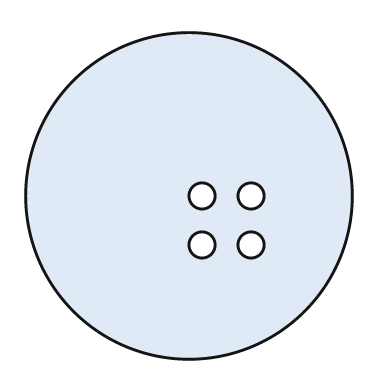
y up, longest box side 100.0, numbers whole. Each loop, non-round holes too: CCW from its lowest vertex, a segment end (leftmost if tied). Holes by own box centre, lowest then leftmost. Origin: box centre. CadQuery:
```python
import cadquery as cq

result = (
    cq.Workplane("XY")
    .moveTo(0.0, 0.0)
    .circle(50.0)
    .moveTo(4.0, -15.0)
    .circle(4.0)
    .moveTo(19.0, -15.0)
    .circle(4.0)
    .moveTo(4.0, 0.0)
    .circle(4.0)
    .moveTo(19.0, 0.0)
    .circle(4.0)
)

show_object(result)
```